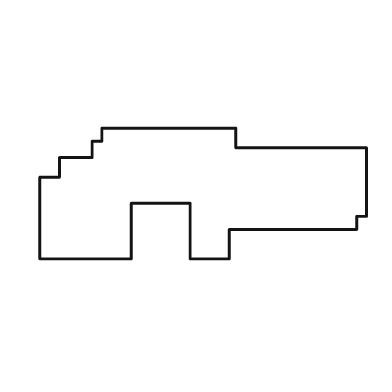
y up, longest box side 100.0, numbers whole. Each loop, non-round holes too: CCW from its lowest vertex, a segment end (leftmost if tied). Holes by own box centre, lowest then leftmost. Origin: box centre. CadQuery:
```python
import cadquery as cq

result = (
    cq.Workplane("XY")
    .moveTo(-50.0, -20.0)
    .lineTo(-22.0, -20.0)
    .lineTo(-22.0, -3.0)
    .lineTo(-4.0, -3.0)
    .lineTo(-4.0, -20.0)
    .lineTo(8.0, -20.0)
    .lineTo(8.0, -11.0)
    .lineTo(47.0, -11.0)
    .lineTo(47.0, -7.0)
    .lineTo(50.0, -7.0)
    .lineTo(50.0, 14.0)
    .lineTo(10.0, 14.0)
    .lineTo(10.0, 20.0)
    .lineTo(-31.0, 20.0)
    .lineTo(-31.0, 16.0)
    .lineTo(-34.0, 16.0)
    .lineTo(-34.0, 11.0)
    .lineTo(-44.0, 11.0)
    .lineTo(-44.0, 5.0)
    .lineTo(-50.0, 5.0)
    .close()
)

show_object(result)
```